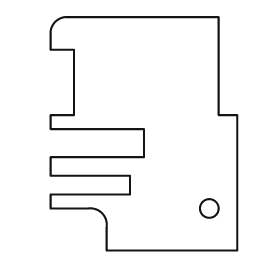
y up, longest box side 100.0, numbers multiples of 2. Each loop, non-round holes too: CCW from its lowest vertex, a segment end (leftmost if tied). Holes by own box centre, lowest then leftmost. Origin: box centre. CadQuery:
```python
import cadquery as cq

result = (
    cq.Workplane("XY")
    .moveTo(-16.0, -50.0)
    .lineTo(40.0, -50.0)
    .lineTo(40.0, 8.0)
    .lineTo(32.0, 8.0)
    .lineTo(32.0, 50.0)
    .lineTo(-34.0, 50.0)
    .threePointArc((-38.0, 48.0), (-40.0, 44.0))
    .lineTo(-40.0, 36.0)
    .lineTo(-30.0, 36.0)
    .lineTo(-30.0, 8.0)
    .lineTo(-40.0, 8.0)
    .lineTo(-40.0, 2.0)
    .lineTo(0.0, 2.0)
    .lineTo(0.0, -10.0)
    .lineTo(-40.0, -10.0)
    .lineTo(-40.0, -18.0)
    .lineTo(-6.0, -18.0)
    .lineTo(-6.0, -26.0)
    .lineTo(-40.0, -26.0)
    .lineTo(-40.0, -32.0)
    .lineTo(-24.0, -32.0)
    .threePointArc((-18.0, -34.0), (-16.0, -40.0))
    .close()
    .moveTo(28.0, -32.0)
    .circle(4.0)
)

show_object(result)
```